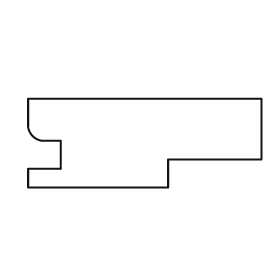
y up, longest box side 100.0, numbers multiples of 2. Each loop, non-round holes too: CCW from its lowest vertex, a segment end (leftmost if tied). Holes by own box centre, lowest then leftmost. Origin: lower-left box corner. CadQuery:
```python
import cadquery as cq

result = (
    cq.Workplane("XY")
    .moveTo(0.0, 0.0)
    .lineTo(60.0, 0.0)
    .lineTo(60.0, 12.0)
    .lineTo(100.0, 12.0)
    .lineTo(100.0, 38.0)
    .lineTo(0.0, 38.0)
    .lineTo(0.0, 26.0)
    .threePointArc((2.0, 22.0), (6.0, 20.0))
    .lineTo(14.0, 20.0)
    .lineTo(14.0, 8.0)
    .lineTo(0.0, 8.0)
    .close()
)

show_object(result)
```